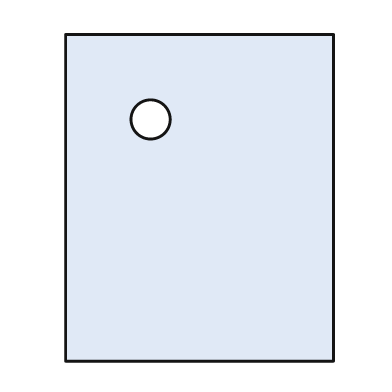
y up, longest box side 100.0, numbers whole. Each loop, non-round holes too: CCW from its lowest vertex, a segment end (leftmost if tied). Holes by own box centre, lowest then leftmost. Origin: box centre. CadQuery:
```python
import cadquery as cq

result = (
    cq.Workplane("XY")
    .moveTo(-41.0, -50.0)
    .lineTo(41.0, -50.0)
    .lineTo(41.0, 50.0)
    .lineTo(-41.0, 50.0)
    .close()
    .moveTo(-15.0, 24.0)
    .circle(6.0)
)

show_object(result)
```